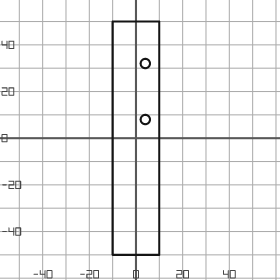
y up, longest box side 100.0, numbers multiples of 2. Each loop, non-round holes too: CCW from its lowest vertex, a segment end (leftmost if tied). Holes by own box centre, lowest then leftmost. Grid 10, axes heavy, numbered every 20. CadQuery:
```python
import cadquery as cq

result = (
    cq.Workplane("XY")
    .moveTo(-10.0, -50.0)
    .lineTo(10.0, -50.0)
    .lineTo(10.0, 50.0)
    .lineTo(-10.0, 50.0)
    .close()
    .moveTo(4.0, 8.0)
    .circle(2.0)
    .moveTo(4.0, 32.0)
    .circle(2.0)
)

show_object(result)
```